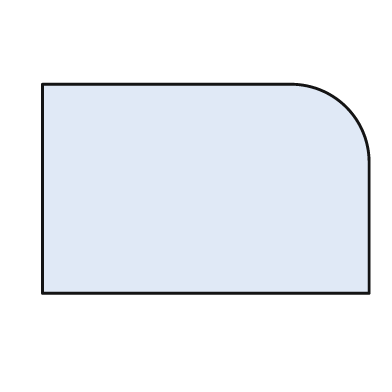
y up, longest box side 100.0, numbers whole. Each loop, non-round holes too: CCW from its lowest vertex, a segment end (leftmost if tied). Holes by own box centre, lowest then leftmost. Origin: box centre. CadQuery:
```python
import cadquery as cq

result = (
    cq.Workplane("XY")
    .moveTo(-50.0, -32.0)
    .lineTo(50.0, -32.0)
    .lineTo(50.0, 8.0)
    .threePointArc((43.0, 25.0), (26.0, 32.0))
    .lineTo(-50.0, 32.0)
    .close()
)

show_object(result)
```